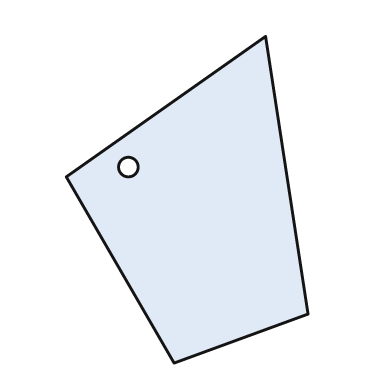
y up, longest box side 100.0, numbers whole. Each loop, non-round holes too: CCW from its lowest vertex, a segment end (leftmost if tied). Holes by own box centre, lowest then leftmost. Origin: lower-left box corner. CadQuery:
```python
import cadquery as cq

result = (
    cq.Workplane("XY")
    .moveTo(33.0, 0.0)
    .lineTo(74.0, 15.0)
    .lineTo(61.0, 100.0)
    .lineTo(0.0, 57.0)
    .close()
    .moveTo(19.0, 60.0)
    .circle(3.0)
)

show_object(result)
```